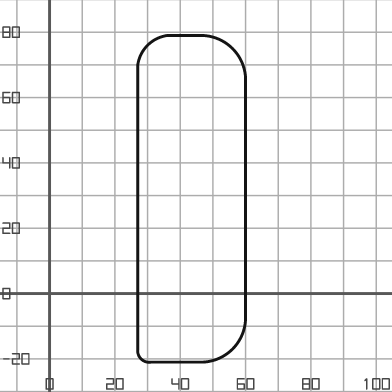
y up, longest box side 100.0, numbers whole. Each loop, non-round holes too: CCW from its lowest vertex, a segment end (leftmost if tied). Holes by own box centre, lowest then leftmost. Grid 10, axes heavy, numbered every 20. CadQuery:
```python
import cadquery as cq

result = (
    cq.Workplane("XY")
    .moveTo(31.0, -21.0)
    .lineTo(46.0, -21.0)
    .threePointArc((56.0, -17.0), (60.0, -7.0))
    .lineTo(60.0, 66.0)
    .threePointArc((56.0, 75.0), (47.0, 79.0))
    .lineTo(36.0, 79.0)
    .threePointArc((30.0, 76.0), (27.0, 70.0))
    .lineTo(27.0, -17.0)
    .threePointArc((28.0, -20.0), (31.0, -21.0))
    .close()
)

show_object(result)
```